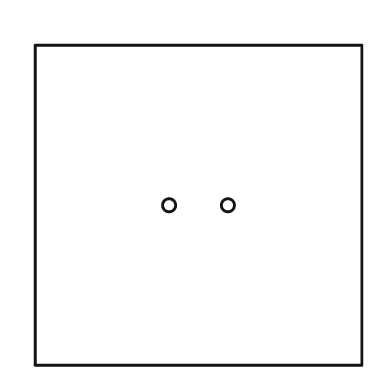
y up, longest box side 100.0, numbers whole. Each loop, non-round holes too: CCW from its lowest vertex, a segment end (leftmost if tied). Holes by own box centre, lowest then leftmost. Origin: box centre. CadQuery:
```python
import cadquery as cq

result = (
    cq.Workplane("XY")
    .moveTo(-50.0, -49.0)
    .lineTo(50.0, -49.0)
    .lineTo(50.0, 49.0)
    .lineTo(-50.0, 49.0)
    .close()
    .moveTo(-9.0, 0.0)
    .circle(2.0)
    .moveTo(9.0, 0.0)
    .circle(2.0)
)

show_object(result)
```